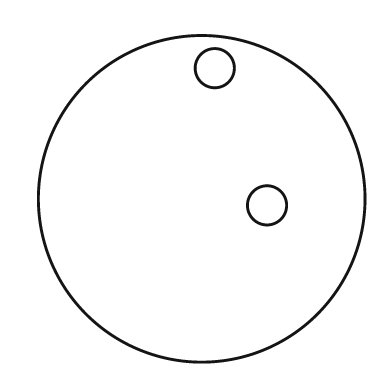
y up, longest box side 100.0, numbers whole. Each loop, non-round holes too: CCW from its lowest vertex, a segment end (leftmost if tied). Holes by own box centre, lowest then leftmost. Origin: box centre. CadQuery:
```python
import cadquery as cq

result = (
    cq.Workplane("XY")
    .moveTo(0.0, 0.0)
    .circle(50.0)
    .moveTo(20.0, -2.0)
    .circle(6.0)
    .moveTo(4.0, 40.0)
    .circle(6.0)
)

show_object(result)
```